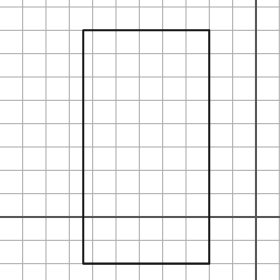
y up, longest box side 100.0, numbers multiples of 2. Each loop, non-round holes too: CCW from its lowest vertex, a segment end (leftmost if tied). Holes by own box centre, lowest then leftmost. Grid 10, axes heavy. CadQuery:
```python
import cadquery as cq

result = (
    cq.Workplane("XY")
    .moveTo(-74.0, -20.0)
    .lineTo(-20.0, -20.0)
    .lineTo(-20.0, 80.0)
    .lineTo(-74.0, 80.0)
    .close()
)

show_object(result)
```